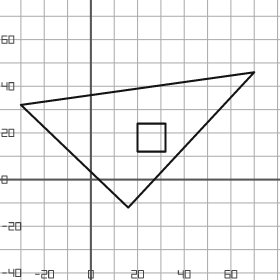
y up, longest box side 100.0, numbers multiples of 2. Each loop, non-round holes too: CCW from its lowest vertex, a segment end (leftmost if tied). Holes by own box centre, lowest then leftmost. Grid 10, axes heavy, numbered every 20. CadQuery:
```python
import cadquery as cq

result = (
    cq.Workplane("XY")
    .moveTo(16.0, -12.0)
    .lineTo(70.0, 46.0)
    .lineTo(-30.0, 32.0)
    .close()
    .moveTo(20.0, 12.0)
    .lineTo(32.0, 12.0)
    .lineTo(32.0, 24.0)
    .lineTo(20.0, 24.0)
    .close()
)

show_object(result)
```